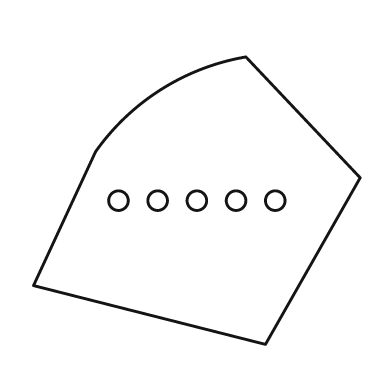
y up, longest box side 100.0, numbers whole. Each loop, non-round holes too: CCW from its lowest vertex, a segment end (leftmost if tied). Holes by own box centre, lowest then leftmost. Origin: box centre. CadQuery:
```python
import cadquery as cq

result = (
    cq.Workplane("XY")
    .moveTo(21.0, -44.0)
    .lineTo(50.0, 7.0)
    .lineTo(15.0, 44.0)
    .threePointArc((-11.0, 34.0), (-31.0, 15.0))
    .lineTo(-50.0, -26.0)
    .close()
    .moveTo(-24.0, 0.0)
    .circle(3.0)
    .moveTo(-12.0, 0.0)
    .circle(3.0)
    .moveTo(0.0, 0.0)
    .circle(3.0)
    .moveTo(12.0, 0.0)
    .circle(3.0)
    .moveTo(24.0, 0.0)
    .circle(3.0)
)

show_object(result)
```